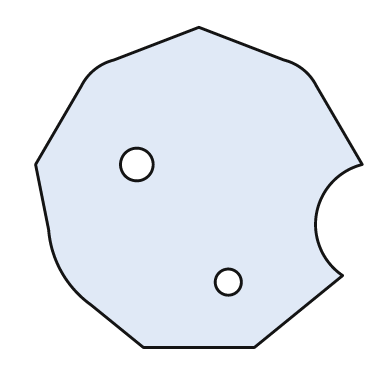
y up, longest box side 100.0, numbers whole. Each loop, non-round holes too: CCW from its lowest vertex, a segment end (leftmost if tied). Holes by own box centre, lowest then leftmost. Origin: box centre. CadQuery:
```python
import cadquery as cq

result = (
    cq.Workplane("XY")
    .moveTo(-17.0, -49.0)
    .lineTo(17.0, -49.0)
    .lineTo(44.0, -27.0)
    .threePointArc((36.0, -8.0), (50.0, 7.0))
    .lineTo(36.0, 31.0)
    .threePointArc((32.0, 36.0), (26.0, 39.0))
    .lineTo(0.0, 49.0)
    .lineTo(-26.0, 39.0)
    .threePointArc((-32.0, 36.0), (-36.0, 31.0))
    .lineTo(-50.0, 7.0)
    .lineTo(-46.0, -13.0)
    .threePointArc((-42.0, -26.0), (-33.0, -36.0))
    .close()
    .moveTo(9.0, -29.0)
    .circle(4.0)
    .moveTo(-19.0, 7.0)
    .circle(5.0)
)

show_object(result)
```